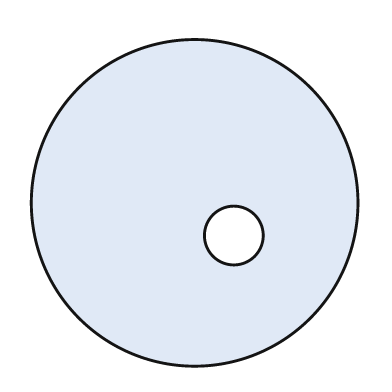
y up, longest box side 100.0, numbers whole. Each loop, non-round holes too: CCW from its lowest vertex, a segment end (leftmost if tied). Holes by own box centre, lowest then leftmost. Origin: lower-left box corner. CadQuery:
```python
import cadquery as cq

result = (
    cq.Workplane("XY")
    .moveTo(50.0, 50.0)
    .circle(50.0)
    .moveTo(62.0, 40.0)
    .circle(9.0)
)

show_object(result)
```